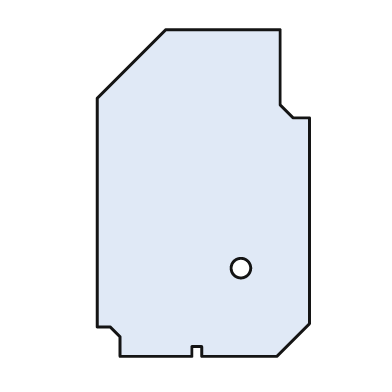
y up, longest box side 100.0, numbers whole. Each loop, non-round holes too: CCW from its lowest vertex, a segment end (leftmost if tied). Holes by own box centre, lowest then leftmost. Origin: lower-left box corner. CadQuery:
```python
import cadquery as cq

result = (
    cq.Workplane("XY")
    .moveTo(7.0, 0.0)
    .lineTo(29.0, 0.0)
    .lineTo(29.0, 3.0)
    .lineTo(32.0, 3.0)
    .lineTo(32.0, 0.0)
    .lineTo(55.0, 0.0)
    .lineTo(65.0, 10.0)
    .lineTo(65.0, 73.0)
    .lineTo(60.0, 73.0)
    .lineTo(56.0, 77.0)
    .lineTo(56.0, 100.0)
    .lineTo(21.0, 100.0)
    .lineTo(0.0, 79.0)
    .lineTo(0.0, 9.0)
    .lineTo(4.0, 9.0)
    .lineTo(7.0, 6.0)
    .close()
    .moveTo(44.0, 27.0)
    .circle(3.0)
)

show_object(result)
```